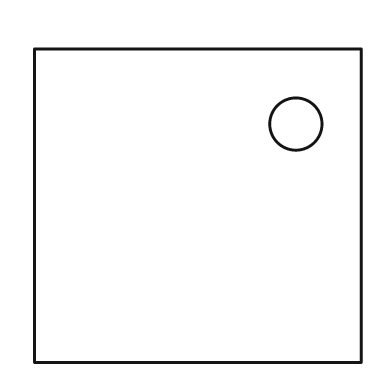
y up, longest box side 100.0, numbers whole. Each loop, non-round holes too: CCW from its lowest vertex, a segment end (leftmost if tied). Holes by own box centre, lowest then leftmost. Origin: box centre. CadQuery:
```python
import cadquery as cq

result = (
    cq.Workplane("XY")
    .moveTo(-50.0, -48.0)
    .lineTo(50.0, -48.0)
    .lineTo(50.0, 48.0)
    .lineTo(-50.0, 48.0)
    .close()
    .moveTo(30.0, 25.0)
    .circle(8.0)
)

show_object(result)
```